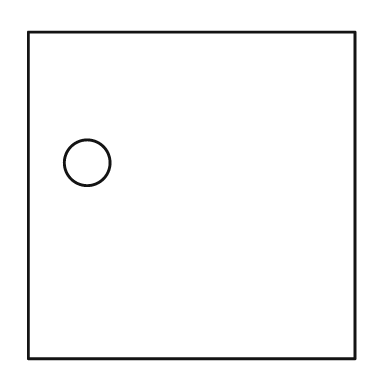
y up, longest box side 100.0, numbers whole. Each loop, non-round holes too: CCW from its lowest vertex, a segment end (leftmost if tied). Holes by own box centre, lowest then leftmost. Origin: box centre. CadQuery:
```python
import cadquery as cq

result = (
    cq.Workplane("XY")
    .moveTo(-50.0, -50.0)
    .lineTo(50.0, -50.0)
    .lineTo(50.0, 50.0)
    .lineTo(-50.0, 50.0)
    .close()
    .moveTo(-32.0, 10.0)
    .circle(7.0)
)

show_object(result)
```